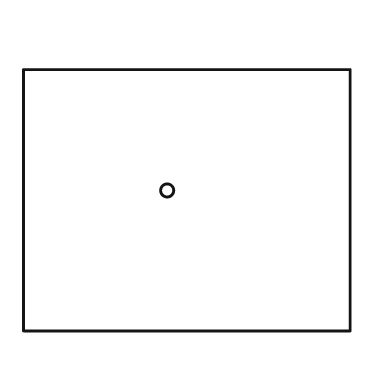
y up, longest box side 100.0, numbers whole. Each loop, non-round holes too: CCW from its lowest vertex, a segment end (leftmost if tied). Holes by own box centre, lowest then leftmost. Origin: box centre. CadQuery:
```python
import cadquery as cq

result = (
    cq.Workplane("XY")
    .moveTo(-50.0, -40.0)
    .lineTo(50.0, -40.0)
    .lineTo(50.0, 40.0)
    .lineTo(-50.0, 40.0)
    .close()
    .moveTo(-6.0, 3.0)
    .circle(2.0)
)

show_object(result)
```